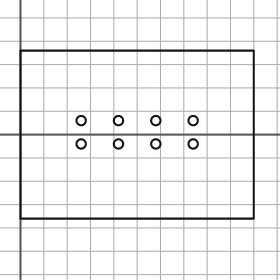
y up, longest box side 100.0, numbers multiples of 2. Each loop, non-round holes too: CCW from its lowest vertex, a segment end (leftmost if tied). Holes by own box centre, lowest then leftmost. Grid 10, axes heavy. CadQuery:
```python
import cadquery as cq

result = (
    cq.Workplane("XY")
    .moveTo(0.0, -36.0)
    .lineTo(100.0, -36.0)
    .lineTo(100.0, 36.0)
    .lineTo(0.0, 36.0)
    .close()
    .moveTo(26.0, -4.0)
    .circle(2.0)
    .moveTo(42.0, -4.0)
    .circle(2.0)
    .moveTo(58.0, -4.0)
    .circle(2.0)
    .moveTo(74.0, -4.0)
    .circle(2.0)
    .moveTo(26.0, 6.0)
    .circle(2.0)
    .moveTo(42.0, 6.0)
    .circle(2.0)
    .moveTo(58.0, 6.0)
    .circle(2.0)
    .moveTo(74.0, 6.0)
    .circle(2.0)
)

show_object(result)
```